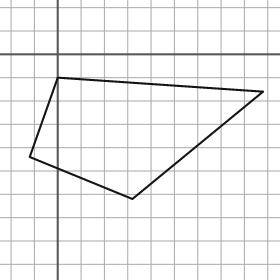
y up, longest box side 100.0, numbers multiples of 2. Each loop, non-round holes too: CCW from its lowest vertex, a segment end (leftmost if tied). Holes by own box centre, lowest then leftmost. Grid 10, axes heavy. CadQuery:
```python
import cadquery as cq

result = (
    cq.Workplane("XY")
    .moveTo(32.0, -62.0)
    .lineTo(88.0, -16.0)
    .lineTo(0.0, -10.0)
    .lineTo(-12.0, -44.0)
    .close()
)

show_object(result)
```